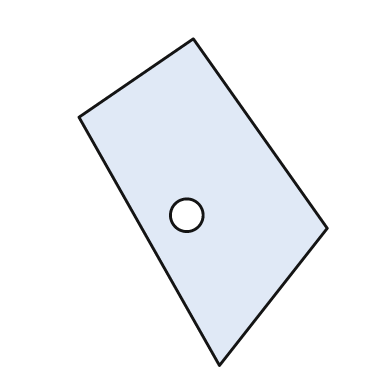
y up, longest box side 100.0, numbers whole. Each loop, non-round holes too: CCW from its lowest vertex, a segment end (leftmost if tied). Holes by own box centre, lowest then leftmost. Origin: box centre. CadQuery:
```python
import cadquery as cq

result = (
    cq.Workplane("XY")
    .moveTo(5.0, -50.0)
    .lineTo(38.0, -8.0)
    .lineTo(-3.0, 50.0)
    .lineTo(-38.0, 26.0)
    .close()
    .moveTo(-5.0, -4.0)
    .circle(5.0)
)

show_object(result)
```